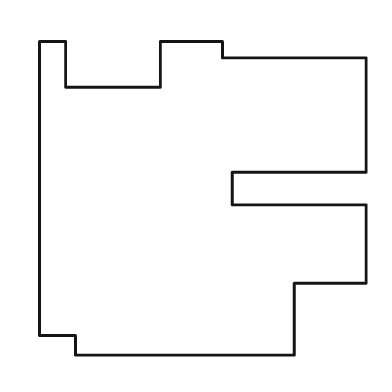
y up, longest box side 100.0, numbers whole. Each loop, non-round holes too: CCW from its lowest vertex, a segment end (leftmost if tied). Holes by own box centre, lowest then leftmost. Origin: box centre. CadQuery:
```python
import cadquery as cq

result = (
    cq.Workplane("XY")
    .moveTo(-39.0, -48.0)
    .lineTo(28.0, -48.0)
    .lineTo(28.0, -26.0)
    .lineTo(50.0, -26.0)
    .lineTo(50.0, -2.0)
    .lineTo(9.0, -2.0)
    .lineTo(9.0, 8.0)
    .lineTo(50.0, 8.0)
    .lineTo(50.0, 43.0)
    .lineTo(6.0, 43.0)
    .lineTo(6.0, 48.0)
    .lineTo(-13.0, 48.0)
    .lineTo(-13.0, 34.0)
    .lineTo(-42.0, 34.0)
    .lineTo(-42.0, 48.0)
    .lineTo(-50.0, 48.0)
    .lineTo(-50.0, -42.0)
    .lineTo(-39.0, -42.0)
    .close()
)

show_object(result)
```